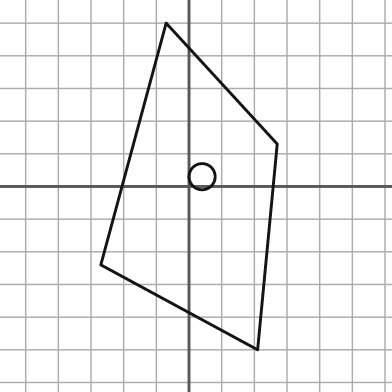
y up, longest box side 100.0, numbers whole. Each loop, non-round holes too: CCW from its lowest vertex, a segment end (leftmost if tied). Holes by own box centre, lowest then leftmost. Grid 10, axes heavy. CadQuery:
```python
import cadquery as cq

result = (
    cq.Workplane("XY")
    .moveTo(21.0, -50.0)
    .lineTo(27.0, 13.0)
    .lineTo(-7.0, 50.0)
    .lineTo(-27.0, -24.0)
    .close()
    .moveTo(4.0, 3.0)
    .circle(4.0)
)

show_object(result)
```